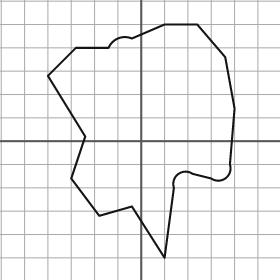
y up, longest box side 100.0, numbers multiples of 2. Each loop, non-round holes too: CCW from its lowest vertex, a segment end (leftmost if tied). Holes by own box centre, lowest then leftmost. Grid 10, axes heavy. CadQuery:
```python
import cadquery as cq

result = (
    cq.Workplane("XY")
    .moveTo(10.0, -50.0)
    .lineTo(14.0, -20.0)
    .threePointArc((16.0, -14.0), (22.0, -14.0))
    .lineTo(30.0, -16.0)
    .threePointArc((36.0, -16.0), (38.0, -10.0))
    .lineTo(40.0, 14.0)
    .lineTo(36.0, 36.0)
    .lineTo(24.0, 50.0)
    .lineTo(10.0, 50.0)
    .lineTo(-4.0, 44.0)
    .threePointArc((-10.0, 44.0), (-14.0, 40.0))
    .lineTo(-28.0, 40.0)
    .lineTo(-40.0, 28.0)
    .lineTo(-24.0, 2.0)
    .lineTo(-30.0, -16.0)
    .lineTo(-18.0, -32.0)
    .lineTo(-4.0, -28.0)
    .close()
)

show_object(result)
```